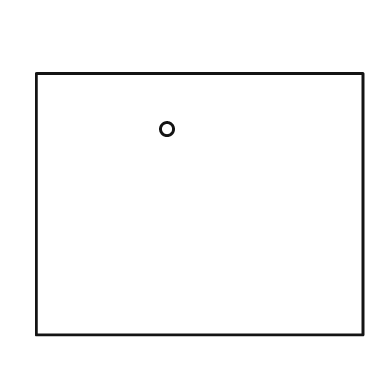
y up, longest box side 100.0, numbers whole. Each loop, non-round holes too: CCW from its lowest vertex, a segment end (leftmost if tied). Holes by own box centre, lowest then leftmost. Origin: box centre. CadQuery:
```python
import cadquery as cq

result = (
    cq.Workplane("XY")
    .moveTo(-50.0, -40.0)
    .lineTo(50.0, -40.0)
    .lineTo(50.0, 40.0)
    .lineTo(-50.0, 40.0)
    .close()
    .moveTo(-10.0, 23.0)
    .circle(2.0)
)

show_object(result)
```